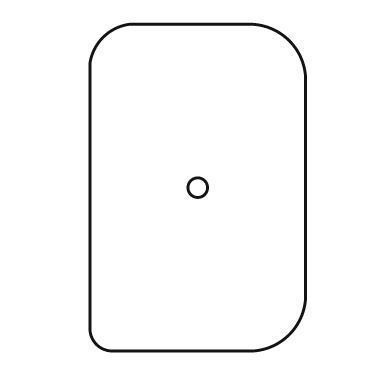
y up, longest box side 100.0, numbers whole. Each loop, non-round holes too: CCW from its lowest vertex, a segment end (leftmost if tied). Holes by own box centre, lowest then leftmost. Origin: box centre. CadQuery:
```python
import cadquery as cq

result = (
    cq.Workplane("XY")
    .moveTo(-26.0, -50.0)
    .lineTo(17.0, -50.0)
    .threePointArc((28.0, -45.0), (33.0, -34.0))
    .lineTo(33.0, 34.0)
    .threePointArc((28.0, 45.0), (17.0, 50.0))
    .lineTo(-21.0, 50.0)
    .threePointArc((-29.0, 46.0), (-33.0, 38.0))
    .lineTo(-33.0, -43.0)
    .threePointArc((-31.0, -48.0), (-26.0, -50.0))
    .close()
    .moveTo(0.0, 0.0)
    .circle(3.0)
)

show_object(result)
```